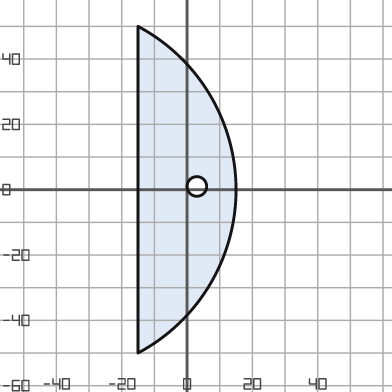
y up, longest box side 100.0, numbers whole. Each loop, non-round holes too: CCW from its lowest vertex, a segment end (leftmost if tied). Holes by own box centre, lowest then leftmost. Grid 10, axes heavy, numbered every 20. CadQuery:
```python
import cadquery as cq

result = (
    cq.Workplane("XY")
    .moveTo(-15.0, -50.0)
    .threePointArc((15.0, 0.0), (-15.0, 50.0))
    .close()
    .moveTo(3.0, 1.0)
    .circle(3.0)
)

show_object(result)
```